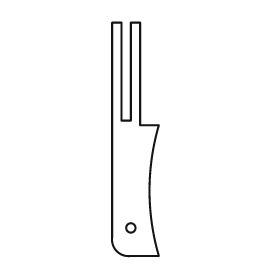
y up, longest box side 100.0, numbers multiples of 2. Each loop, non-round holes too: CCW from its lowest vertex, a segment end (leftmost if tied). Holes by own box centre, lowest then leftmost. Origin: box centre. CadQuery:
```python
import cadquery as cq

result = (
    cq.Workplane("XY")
    .moveTo(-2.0, -50.0)
    .lineTo(10.0, -50.0)
    .threePointArc((6.0, -22.0), (10.0, 6.0))
    .lineTo(2.0, 6.0)
    .lineTo(2.0, 50.0)
    .lineTo(-2.0, 50.0)
    .lineTo(-2.0, 8.0)
    .lineTo(-6.0, 8.0)
    .lineTo(-6.0, 50.0)
    .lineTo(-10.0, 50.0)
    .lineTo(-10.0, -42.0)
    .threePointArc((-8.0, -48.0), (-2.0, -50.0))
    .close()
    .moveTo(-2.0, -38.0)
    .circle(2.0)
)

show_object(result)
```